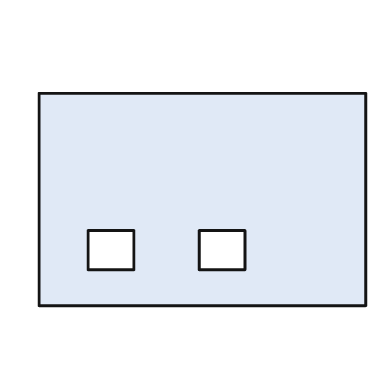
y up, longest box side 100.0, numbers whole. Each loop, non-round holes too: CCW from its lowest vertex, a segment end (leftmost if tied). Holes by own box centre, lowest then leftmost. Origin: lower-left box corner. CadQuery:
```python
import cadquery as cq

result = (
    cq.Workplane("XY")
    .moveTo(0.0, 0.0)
    .lineTo(100.0, 0.0)
    .lineTo(100.0, 65.0)
    .lineTo(0.0, 65.0)
    .close()
    .moveTo(15.0, 11.0)
    .lineTo(29.0, 11.0)
    .lineTo(29.0, 23.0)
    .lineTo(15.0, 23.0)
    .close()
    .moveTo(49.0, 11.0)
    .lineTo(63.0, 11.0)
    .lineTo(63.0, 23.0)
    .lineTo(49.0, 23.0)
    .close()
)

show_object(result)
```